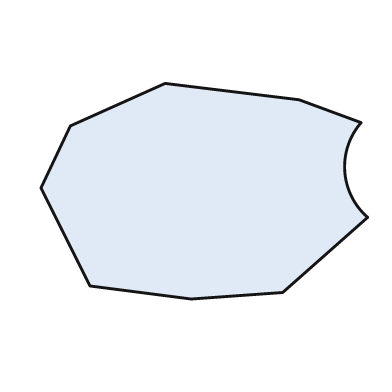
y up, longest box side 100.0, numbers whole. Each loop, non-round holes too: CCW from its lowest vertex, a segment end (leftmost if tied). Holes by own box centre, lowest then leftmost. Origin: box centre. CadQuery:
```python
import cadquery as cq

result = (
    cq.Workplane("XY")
    .moveTo(-4.0, -33.0)
    .lineTo(24.0, -31.0)
    .lineTo(50.0, -8.0)
    .threePointArc((43.0, 6.0), (48.0, 21.0))
    .lineTo(29.0, 28.0)
    .lineTo(-12.0, 33.0)
    .lineTo(-41.0, 20.0)
    .lineTo(-50.0, 1.0)
    .lineTo(-35.0, -29.0)
    .close()
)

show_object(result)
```